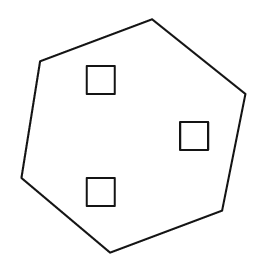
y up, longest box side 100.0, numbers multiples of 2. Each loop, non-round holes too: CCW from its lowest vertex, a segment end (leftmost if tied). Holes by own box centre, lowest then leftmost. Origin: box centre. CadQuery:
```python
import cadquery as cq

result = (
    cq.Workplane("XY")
    .moveTo(-10.0, -50.0)
    .lineTo(38.0, -32.0)
    .lineTo(48.0, 18.0)
    .lineTo(8.0, 50.0)
    .lineTo(-40.0, 32.0)
    .lineTo(-48.0, -18.0)
    .close()
    .moveTo(-20.0, -30.0)
    .lineTo(-8.0, -30.0)
    .lineTo(-8.0, -18.0)
    .lineTo(-20.0, -18.0)
    .close()
    .moveTo(20.0, -6.0)
    .lineTo(32.0, -6.0)
    .lineTo(32.0, 6.0)
    .lineTo(20.0, 6.0)
    .close()
    .moveTo(-20.0, 18.0)
    .lineTo(-8.0, 18.0)
    .lineTo(-8.0, 30.0)
    .lineTo(-20.0, 30.0)
    .close()
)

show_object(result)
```